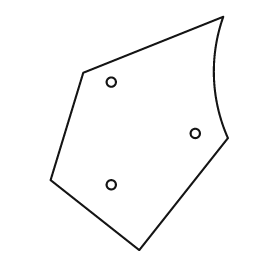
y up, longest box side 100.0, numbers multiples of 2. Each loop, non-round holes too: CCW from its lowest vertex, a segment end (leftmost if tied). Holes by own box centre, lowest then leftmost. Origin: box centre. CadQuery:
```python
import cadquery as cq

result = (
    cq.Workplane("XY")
    .moveTo(0.0, -50.0)
    .lineTo(38.0, -2.0)
    .threePointArc((32.0, 24.0), (36.0, 50.0))
    .lineTo(-24.0, 26.0)
    .lineTo(-38.0, -20.0)
    .close()
    .moveTo(-12.0, -22.0)
    .circle(2.0)
    .moveTo(24.0, 0.0)
    .circle(2.0)
    .moveTo(-12.0, 22.0)
    .circle(2.0)
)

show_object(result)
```